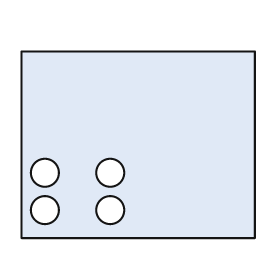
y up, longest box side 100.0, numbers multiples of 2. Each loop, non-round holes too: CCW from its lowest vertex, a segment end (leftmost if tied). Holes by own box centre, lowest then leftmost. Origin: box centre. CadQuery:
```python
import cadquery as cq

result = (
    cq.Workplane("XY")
    .moveTo(-50.0, -40.0)
    .lineTo(50.0, -40.0)
    .lineTo(50.0, 40.0)
    .lineTo(-50.0, 40.0)
    .close()
    .moveTo(-40.0, -28.0)
    .circle(6.0)
    .moveTo(-12.0, -28.0)
    .circle(6.0)
    .moveTo(-40.0, -12.0)
    .circle(6.0)
    .moveTo(-12.0, -12.0)
    .circle(6.0)
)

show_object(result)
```